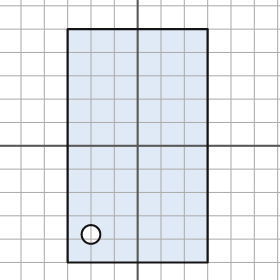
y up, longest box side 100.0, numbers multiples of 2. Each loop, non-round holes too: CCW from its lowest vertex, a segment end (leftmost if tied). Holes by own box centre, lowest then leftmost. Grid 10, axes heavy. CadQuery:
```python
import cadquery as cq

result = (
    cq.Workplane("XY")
    .moveTo(-30.0, -50.0)
    .lineTo(30.0, -50.0)
    .lineTo(30.0, 50.0)
    .lineTo(-30.0, 50.0)
    .close()
    .moveTo(-20.0, -38.0)
    .circle(4.0)
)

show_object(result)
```